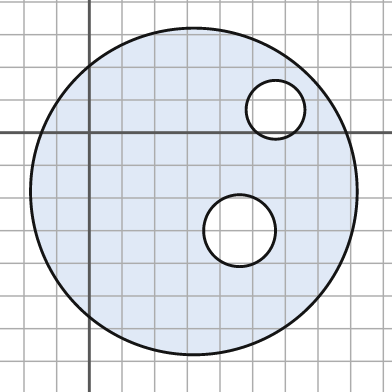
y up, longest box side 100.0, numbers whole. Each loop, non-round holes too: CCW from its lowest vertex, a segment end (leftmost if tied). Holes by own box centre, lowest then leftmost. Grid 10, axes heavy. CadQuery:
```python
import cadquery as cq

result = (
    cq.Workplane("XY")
    .moveTo(32.0, -18.0)
    .circle(50.0)
    .moveTo(46.0, -30.0)
    .circle(11.0)
    .moveTo(57.0, 7.0)
    .circle(9.0)
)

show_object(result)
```